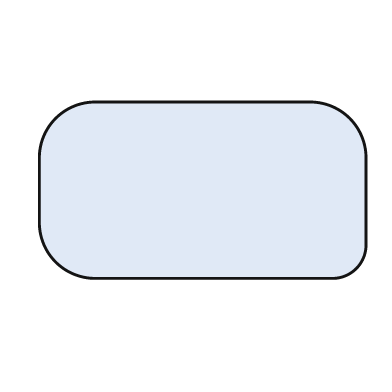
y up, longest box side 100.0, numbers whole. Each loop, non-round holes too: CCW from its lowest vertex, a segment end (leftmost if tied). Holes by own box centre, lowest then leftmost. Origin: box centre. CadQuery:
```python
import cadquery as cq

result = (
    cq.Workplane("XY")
    .moveTo(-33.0, -27.0)
    .lineTo(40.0, -27.0)
    .threePointArc((47.0, -24.0), (50.0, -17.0))
    .lineTo(50.0, 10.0)
    .threePointArc((45.0, 22.0), (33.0, 27.0))
    .lineTo(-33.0, 27.0)
    .threePointArc((-45.0, 22.0), (-50.0, 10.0))
    .lineTo(-50.0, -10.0)
    .threePointArc((-45.0, -22.0), (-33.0, -27.0))
    .close()
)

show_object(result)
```